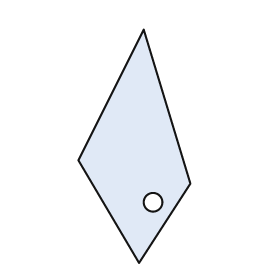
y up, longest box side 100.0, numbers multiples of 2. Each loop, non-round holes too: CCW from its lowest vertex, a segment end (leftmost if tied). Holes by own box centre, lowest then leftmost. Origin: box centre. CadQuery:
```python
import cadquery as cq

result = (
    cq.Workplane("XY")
    .moveTo(2.0, -50.0)
    .lineTo(24.0, -16.0)
    .lineTo(4.0, 50.0)
    .lineTo(-24.0, -6.0)
    .close()
    .moveTo(8.0, -24.0)
    .circle(4.0)
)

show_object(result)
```